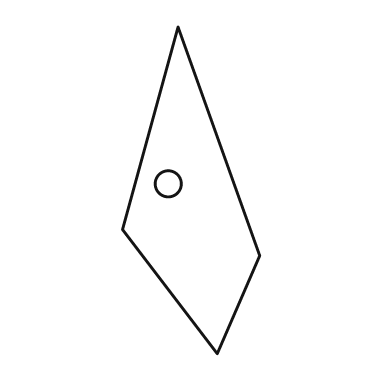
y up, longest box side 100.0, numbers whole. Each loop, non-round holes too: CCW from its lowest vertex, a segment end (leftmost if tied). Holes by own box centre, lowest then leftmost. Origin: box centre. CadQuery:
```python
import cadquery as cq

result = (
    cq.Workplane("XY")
    .moveTo(8.0, -50.0)
    .lineTo(21.0, -20.0)
    .lineTo(-4.0, 50.0)
    .lineTo(-21.0, -12.0)
    .close()
    .moveTo(-7.0, 2.0)
    .circle(4.0)
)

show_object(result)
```